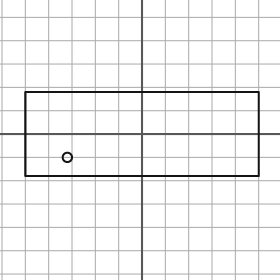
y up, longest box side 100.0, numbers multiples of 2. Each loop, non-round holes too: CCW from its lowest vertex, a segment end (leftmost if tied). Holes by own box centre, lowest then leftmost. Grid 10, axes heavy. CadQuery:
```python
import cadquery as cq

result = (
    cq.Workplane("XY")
    .moveTo(-50.0, -18.0)
    .lineTo(50.0, -18.0)
    .lineTo(50.0, 18.0)
    .lineTo(-50.0, 18.0)
    .close()
    .moveTo(-32.0, -10.0)
    .circle(2.0)
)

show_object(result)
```